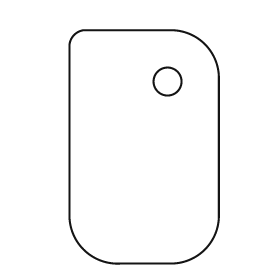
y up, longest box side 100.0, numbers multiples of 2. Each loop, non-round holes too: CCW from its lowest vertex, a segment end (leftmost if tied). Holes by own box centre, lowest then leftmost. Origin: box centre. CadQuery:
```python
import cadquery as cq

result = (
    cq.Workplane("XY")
    .moveTo(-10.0, -50.0)
    .lineTo(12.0, -50.0)
    .threePointArc((26.0, -44.0), (32.0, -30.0))
    .lineTo(32.0, 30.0)
    .threePointArc((26.0, 44.0), (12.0, 50.0))
    .lineTo(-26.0, 50.0)
    .threePointArc((-30.0, 48.0), (-32.0, 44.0))
    .lineTo(-32.0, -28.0)
    .threePointArc((-26.0, -44.0), (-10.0, -50.0))
    .close()
    .moveTo(10.0, 28.0)
    .circle(6.0)
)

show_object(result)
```